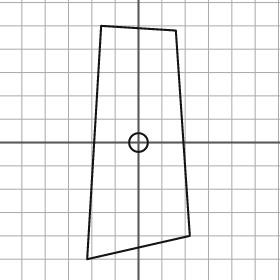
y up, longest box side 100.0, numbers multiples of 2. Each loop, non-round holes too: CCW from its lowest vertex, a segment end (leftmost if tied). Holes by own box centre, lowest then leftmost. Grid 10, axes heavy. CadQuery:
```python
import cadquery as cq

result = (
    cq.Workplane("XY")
    .moveTo(-22.0, -50.0)
    .lineTo(22.0, -40.0)
    .lineTo(16.0, 48.0)
    .lineTo(-16.0, 50.0)
    .close()
    .moveTo(0.0, 0.0)
    .circle(4.0)
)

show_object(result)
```